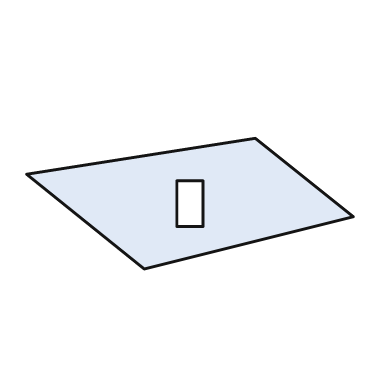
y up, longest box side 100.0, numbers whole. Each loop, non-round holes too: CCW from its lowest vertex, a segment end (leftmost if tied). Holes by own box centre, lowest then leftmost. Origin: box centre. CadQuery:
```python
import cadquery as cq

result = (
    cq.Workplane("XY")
    .moveTo(-14.0, -20.0)
    .lineTo(50.0, -4.0)
    .lineTo(20.0, 20.0)
    .lineTo(-50.0, 9.0)
    .close()
    .moveTo(-4.0, -7.0)
    .lineTo(4.0, -7.0)
    .lineTo(4.0, 7.0)
    .lineTo(-4.0, 7.0)
    .close()
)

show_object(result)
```